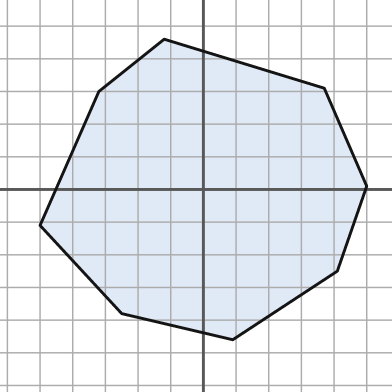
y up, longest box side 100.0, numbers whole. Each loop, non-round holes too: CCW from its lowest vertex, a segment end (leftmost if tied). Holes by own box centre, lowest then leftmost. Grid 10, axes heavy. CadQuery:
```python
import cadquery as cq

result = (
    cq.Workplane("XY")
    .moveTo(9.0, -46.0)
    .lineTo(41.0, -25.0)
    .lineTo(50.0, 1.0)
    .lineTo(37.0, 31.0)
    .lineTo(-12.0, 46.0)
    .lineTo(-32.0, 30.0)
    .lineTo(-50.0, -11.0)
    .lineTo(-25.0, -38.0)
    .close()
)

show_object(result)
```